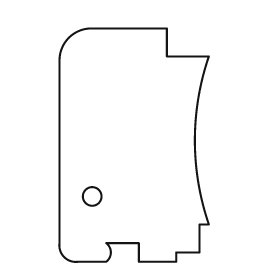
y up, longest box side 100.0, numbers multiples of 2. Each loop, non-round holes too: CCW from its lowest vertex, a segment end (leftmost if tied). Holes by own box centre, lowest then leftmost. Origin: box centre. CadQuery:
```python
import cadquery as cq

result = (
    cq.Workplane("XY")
    .moveTo(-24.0, -50.0)
    .lineTo(-12.0, -50.0)
    .threePointArc((-10.0, -46.0), (-12.0, -42.0))
    .lineTo(2.0, -42.0)
    .lineTo(2.0, -50.0)
    .lineTo(18.0, -50.0)
    .lineTo(18.0, -46.0)
    .lineTo(28.0, -46.0)
    .lineTo(28.0, -34.0)
    .lineTo(32.0, -34.0)
    .threePointArc((26.0, 2.0), (32.0, 38.0))
    .lineTo(14.0, 38.0)
    .lineTo(14.0, 50.0)
    .lineTo(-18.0, 50.0)
    .threePointArc((-28.0, 46.0), (-32.0, 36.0))
    .lineTo(-32.0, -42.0)
    .threePointArc((-30.0, -48.0), (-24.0, -50.0))
    .close()
    .moveTo(-18.0, -22.0)
    .circle(4.0)
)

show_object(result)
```